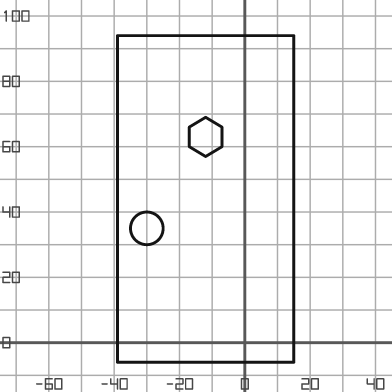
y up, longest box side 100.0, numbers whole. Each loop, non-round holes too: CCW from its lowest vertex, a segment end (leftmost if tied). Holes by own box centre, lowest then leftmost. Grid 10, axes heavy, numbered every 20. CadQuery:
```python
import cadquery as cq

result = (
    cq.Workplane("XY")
    .moveTo(-39.0, -6.0)
    .lineTo(15.0, -6.0)
    .lineTo(15.0, 94.0)
    .lineTo(-39.0, 94.0)
    .close()
    .moveTo(-30.0, 35.0)
    .circle(5.0)
    .moveTo(-12.0, 57.0)
    .lineTo(-7.0, 60.0)
    .lineTo(-7.0, 66.0)
    .lineTo(-12.0, 69.0)
    .lineTo(-17.0, 66.0)
    .lineTo(-17.0, 60.0)
    .close()
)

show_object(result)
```